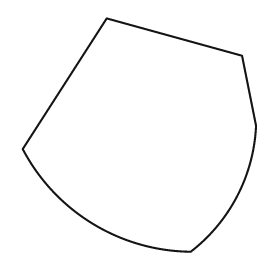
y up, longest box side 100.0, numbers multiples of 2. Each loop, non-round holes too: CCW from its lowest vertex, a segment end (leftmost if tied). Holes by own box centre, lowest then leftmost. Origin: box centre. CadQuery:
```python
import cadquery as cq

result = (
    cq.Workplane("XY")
    .moveTo(22.0, -50.0)
    .threePointArc((42.0, -26.0), (50.0, 4.0))
    .lineTo(44.0, 34.0)
    .lineTo(-14.0, 50.0)
    .lineTo(-50.0, -6.0)
    .threePointArc((-20.0, -38.0), (22.0, -50.0))
    .close()
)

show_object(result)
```